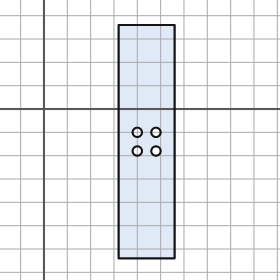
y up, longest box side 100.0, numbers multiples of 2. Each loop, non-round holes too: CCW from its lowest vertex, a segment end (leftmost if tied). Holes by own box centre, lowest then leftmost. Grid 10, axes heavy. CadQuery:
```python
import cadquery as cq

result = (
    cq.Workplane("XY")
    .moveTo(32.0, -64.0)
    .lineTo(56.0, -64.0)
    .lineTo(56.0, 36.0)
    .lineTo(32.0, 36.0)
    .close()
    .moveTo(40.0, -18.0)
    .circle(2.0)
    .moveTo(48.0, -18.0)
    .circle(2.0)
    .moveTo(40.0, -10.0)
    .circle(2.0)
    .moveTo(48.0, -10.0)
    .circle(2.0)
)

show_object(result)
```